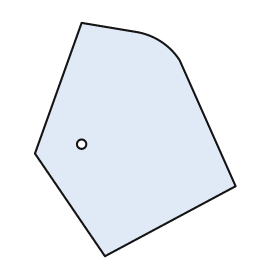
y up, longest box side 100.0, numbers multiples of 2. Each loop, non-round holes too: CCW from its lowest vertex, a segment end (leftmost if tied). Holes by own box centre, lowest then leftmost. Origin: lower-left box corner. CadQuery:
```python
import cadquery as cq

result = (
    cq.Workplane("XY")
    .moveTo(30.0, 0.0)
    .lineTo(86.0, 30.0)
    .lineTo(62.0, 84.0)
    .threePointArc((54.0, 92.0), (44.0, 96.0))
    .lineTo(20.0, 100.0)
    .lineTo(0.0, 44.0)
    .close()
    .moveTo(20.0, 48.0)
    .circle(2.0)
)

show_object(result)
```